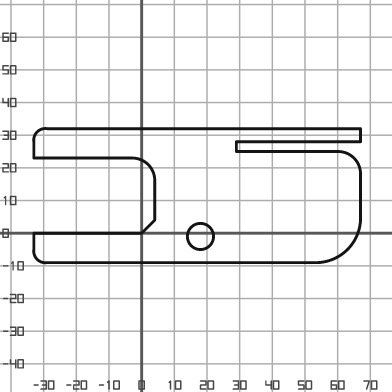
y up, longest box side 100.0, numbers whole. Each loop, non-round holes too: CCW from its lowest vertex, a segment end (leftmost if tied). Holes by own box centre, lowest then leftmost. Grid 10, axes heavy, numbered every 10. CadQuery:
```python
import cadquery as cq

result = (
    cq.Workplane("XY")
    .moveTo(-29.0, -9.0)
    .lineTo(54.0, -9.0)
    .threePointArc((63.0, -5.0), (67.0, 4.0))
    .lineTo(67.0, 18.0)
    .threePointArc((65.0, 23.0), (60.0, 25.0))
    .lineTo(29.0, 25.0)
    .lineTo(29.0, 28.0)
    .lineTo(67.0, 28.0)
    .lineTo(67.0, 32.0)
    .lineTo(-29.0, 32.0)
    .threePointArc((-32.0, 31.0), (-33.0, 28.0))
    .lineTo(-33.0, 23.0)
    .lineTo(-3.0, 23.0)
    .threePointArc((2.0, 21.0), (4.0, 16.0))
    .lineTo(4.0, 4.0)
    .lineTo(0.0, 0.0)
    .lineTo(-33.0, 0.0)
    .lineTo(-33.0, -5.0)
    .threePointArc((-32.0, -8.0), (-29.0, -9.0))
    .close()
    .moveTo(18.0, -1.0)
    .circle(4.0)
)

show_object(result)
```